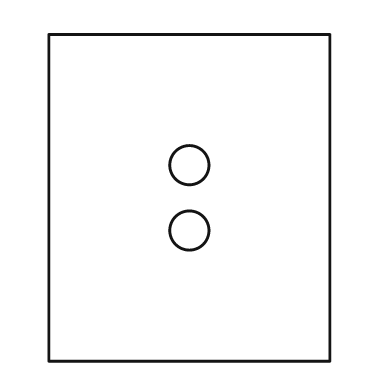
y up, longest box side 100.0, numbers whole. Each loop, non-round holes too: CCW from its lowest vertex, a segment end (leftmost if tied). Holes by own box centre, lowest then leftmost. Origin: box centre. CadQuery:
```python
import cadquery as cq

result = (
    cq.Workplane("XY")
    .moveTo(-43.0, -50.0)
    .lineTo(43.0, -50.0)
    .lineTo(43.0, 50.0)
    .lineTo(-43.0, 50.0)
    .close()
    .moveTo(0.0, -10.0)
    .circle(6.0)
    .moveTo(0.0, 10.0)
    .circle(6.0)
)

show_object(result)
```